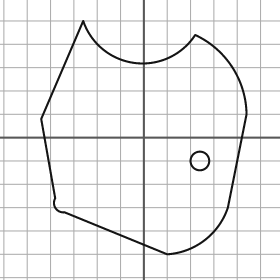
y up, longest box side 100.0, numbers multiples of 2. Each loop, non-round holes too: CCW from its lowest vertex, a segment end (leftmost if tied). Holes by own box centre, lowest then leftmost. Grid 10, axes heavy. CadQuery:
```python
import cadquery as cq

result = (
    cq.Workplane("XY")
    .moveTo(10.0, -50.0)
    .threePointArc((26.0, -44.0), (36.0, -30.0))
    .lineTo(44.0, 10.0)
    .threePointArc((38.0, 30.0), (22.0, 44.0))
    .threePointArc((-4.0, 32.0), (-26.0, 50.0))
    .lineTo(-44.0, 8.0)
    .lineTo(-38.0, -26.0)
    .threePointArc((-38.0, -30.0), (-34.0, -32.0))
    .close()
    .moveTo(24.0, -10.0)
    .circle(4.0)
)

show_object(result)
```